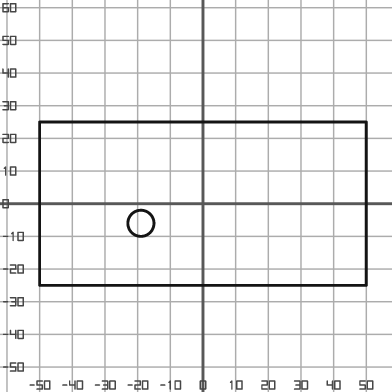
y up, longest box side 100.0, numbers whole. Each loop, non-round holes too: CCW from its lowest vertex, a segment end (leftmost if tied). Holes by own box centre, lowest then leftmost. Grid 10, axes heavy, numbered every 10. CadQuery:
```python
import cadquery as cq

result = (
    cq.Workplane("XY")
    .moveTo(-50.0, -25.0)
    .lineTo(50.0, -25.0)
    .lineTo(50.0, 25.0)
    .lineTo(-50.0, 25.0)
    .close()
    .moveTo(-19.0, -6.0)
    .circle(4.0)
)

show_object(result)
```